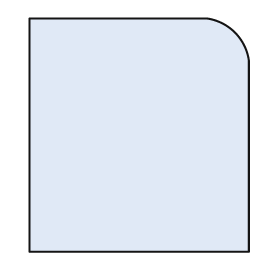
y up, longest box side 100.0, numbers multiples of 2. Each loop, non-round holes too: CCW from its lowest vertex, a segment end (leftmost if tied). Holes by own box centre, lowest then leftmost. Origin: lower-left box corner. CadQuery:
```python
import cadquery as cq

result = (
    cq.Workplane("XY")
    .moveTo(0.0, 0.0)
    .lineTo(94.0, 0.0)
    .lineTo(94.0, 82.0)
    .threePointArc((88.0, 94.0), (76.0, 100.0))
    .lineTo(0.0, 100.0)
    .close()
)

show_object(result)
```